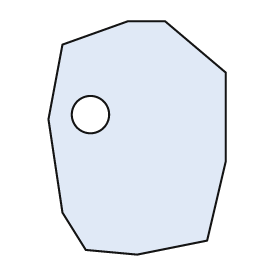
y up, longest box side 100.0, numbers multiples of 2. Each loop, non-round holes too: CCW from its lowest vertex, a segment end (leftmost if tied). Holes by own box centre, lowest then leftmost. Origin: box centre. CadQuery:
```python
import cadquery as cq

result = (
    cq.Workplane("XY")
    .moveTo(0.0, -50.0)
    .lineTo(30.0, -44.0)
    .lineTo(38.0, -10.0)
    .lineTo(38.0, 28.0)
    .lineTo(12.0, 50.0)
    .lineTo(-4.0, 50.0)
    .lineTo(-32.0, 40.0)
    .lineTo(-38.0, 8.0)
    .lineTo(-32.0, -32.0)
    .lineTo(-22.0, -48.0)
    .close()
    .moveTo(-20.0, 10.0)
    .circle(8.0)
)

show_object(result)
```